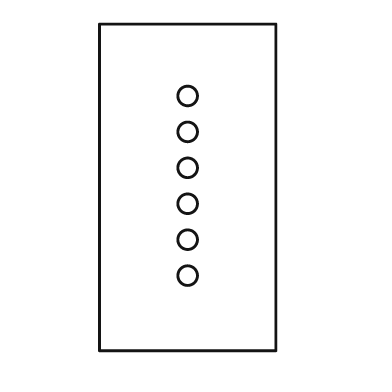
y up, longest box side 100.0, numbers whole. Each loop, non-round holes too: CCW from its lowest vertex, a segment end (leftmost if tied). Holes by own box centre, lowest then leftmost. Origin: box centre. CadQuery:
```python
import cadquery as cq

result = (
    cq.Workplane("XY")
    .moveTo(-27.0, -50.0)
    .lineTo(27.0, -50.0)
    .lineTo(27.0, 50.0)
    .lineTo(-27.0, 50.0)
    .close()
    .moveTo(0.0, -27.0)
    .circle(3.0)
    .moveTo(0.0, -16.0)
    .circle(3.0)
    .moveTo(0.0, -5.0)
    .circle(3.0)
    .moveTo(0.0, 6.0)
    .circle(3.0)
    .moveTo(0.0, 17.0)
    .circle(3.0)
    .moveTo(0.0, 28.0)
    .circle(3.0)
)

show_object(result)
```